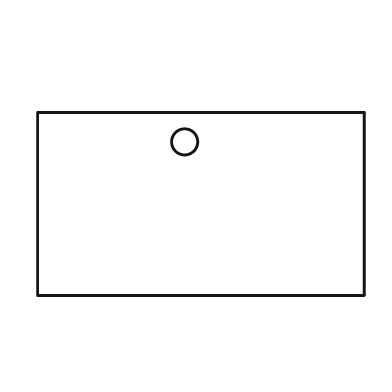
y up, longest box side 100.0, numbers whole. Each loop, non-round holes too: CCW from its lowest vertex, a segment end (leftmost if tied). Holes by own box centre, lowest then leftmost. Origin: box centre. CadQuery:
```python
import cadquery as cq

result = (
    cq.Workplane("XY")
    .moveTo(-50.0, -28.0)
    .lineTo(50.0, -28.0)
    .lineTo(50.0, 28.0)
    .lineTo(-50.0, 28.0)
    .close()
    .moveTo(-5.0, 19.0)
    .circle(4.0)
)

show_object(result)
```